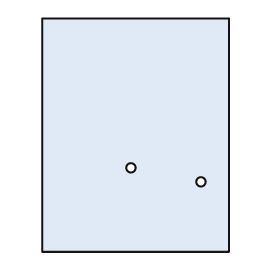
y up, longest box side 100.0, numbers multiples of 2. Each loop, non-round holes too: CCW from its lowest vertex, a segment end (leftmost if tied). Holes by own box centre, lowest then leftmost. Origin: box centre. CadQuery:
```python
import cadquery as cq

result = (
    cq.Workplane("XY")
    .moveTo(-40.0, -50.0)
    .lineTo(40.0, -50.0)
    .lineTo(40.0, 50.0)
    .lineTo(-40.0, 50.0)
    .close()
    .moveTo(28.0, -20.0)
    .circle(2.0)
    .moveTo(-2.0, -14.0)
    .circle(2.0)
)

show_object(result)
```